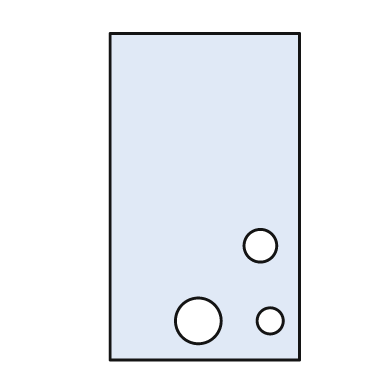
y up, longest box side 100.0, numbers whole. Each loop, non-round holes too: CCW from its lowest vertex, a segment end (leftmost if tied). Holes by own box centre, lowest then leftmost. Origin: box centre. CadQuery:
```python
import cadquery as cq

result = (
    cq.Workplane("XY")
    .moveTo(-29.0, -50.0)
    .lineTo(29.0, -50.0)
    .lineTo(29.0, 50.0)
    .lineTo(-29.0, 50.0)
    .close()
    .moveTo(-2.0, -38.0)
    .circle(7.0)
    .moveTo(20.0, -38.0)
    .circle(4.0)
    .moveTo(17.0, -15.0)
    .circle(5.0)
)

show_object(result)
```